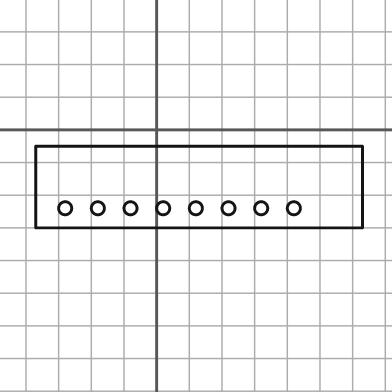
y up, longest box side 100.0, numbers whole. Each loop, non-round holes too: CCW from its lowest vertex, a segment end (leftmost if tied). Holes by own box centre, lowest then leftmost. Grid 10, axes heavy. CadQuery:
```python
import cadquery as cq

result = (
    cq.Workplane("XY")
    .moveTo(-37.0, -30.0)
    .lineTo(63.0, -30.0)
    .lineTo(63.0, -5.0)
    .lineTo(-37.0, -5.0)
    .close()
    .moveTo(-28.0, -24.0)
    .circle(2.0)
    .moveTo(-18.0, -24.0)
    .circle(2.0)
    .moveTo(-8.0, -24.0)
    .circle(2.0)
    .moveTo(2.0, -24.0)
    .circle(2.0)
    .moveTo(12.0, -24.0)
    .circle(2.0)
    .moveTo(22.0, -24.0)
    .circle(2.0)
    .moveTo(32.0, -24.0)
    .circle(2.0)
    .moveTo(42.0, -24.0)
    .circle(2.0)
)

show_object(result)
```